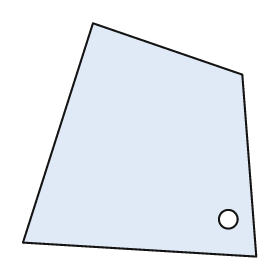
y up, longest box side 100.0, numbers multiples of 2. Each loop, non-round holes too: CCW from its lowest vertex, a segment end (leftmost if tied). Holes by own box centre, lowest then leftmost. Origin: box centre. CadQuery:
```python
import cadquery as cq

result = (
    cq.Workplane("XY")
    .moveTo(50.0, -50.0)
    .lineTo(44.0, 28.0)
    .lineTo(-20.0, 50.0)
    .lineTo(-50.0, -44.0)
    .close()
    .moveTo(38.0, -34.0)
    .circle(4.0)
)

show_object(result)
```